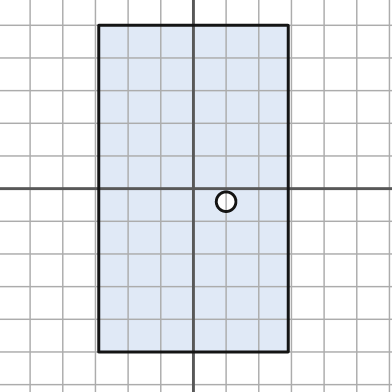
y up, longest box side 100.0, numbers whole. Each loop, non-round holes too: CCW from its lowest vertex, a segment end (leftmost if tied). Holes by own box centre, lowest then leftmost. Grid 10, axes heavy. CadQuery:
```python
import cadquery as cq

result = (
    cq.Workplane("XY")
    .moveTo(-29.0, -50.0)
    .lineTo(29.0, -50.0)
    .lineTo(29.0, 50.0)
    .lineTo(-29.0, 50.0)
    .close()
    .moveTo(10.0, -4.0)
    .circle(3.0)
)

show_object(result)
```